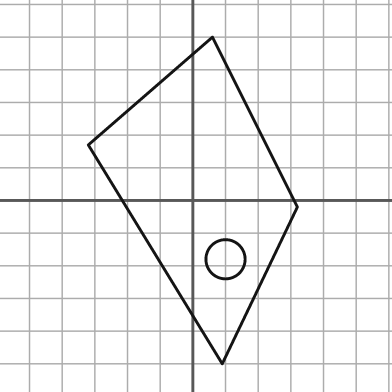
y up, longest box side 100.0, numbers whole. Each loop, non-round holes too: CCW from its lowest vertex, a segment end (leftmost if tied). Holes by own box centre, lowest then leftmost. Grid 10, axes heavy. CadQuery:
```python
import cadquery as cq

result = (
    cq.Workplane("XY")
    .moveTo(9.0, -50.0)
    .lineTo(32.0, -2.0)
    .lineTo(6.0, 50.0)
    .lineTo(-32.0, 17.0)
    .close()
    .moveTo(10.0, -18.0)
    .circle(6.0)
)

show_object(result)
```